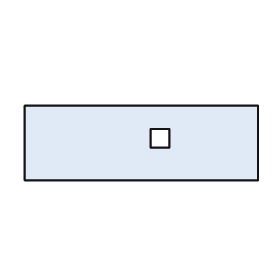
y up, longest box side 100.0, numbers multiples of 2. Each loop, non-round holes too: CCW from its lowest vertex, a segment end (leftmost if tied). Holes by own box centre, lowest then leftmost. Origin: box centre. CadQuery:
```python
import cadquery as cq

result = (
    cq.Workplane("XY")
    .moveTo(-50.0, -16.0)
    .lineTo(50.0, -16.0)
    .lineTo(50.0, 16.0)
    .lineTo(-50.0, 16.0)
    .close()
    .moveTo(4.0, -2.0)
    .lineTo(12.0, -2.0)
    .lineTo(12.0, 6.0)
    .lineTo(4.0, 6.0)
    .close()
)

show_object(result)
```